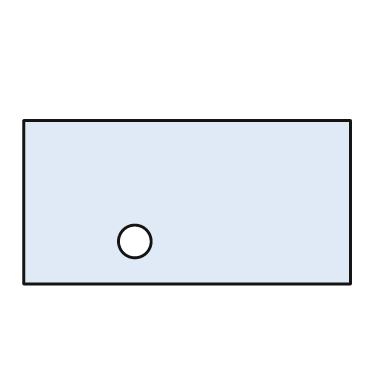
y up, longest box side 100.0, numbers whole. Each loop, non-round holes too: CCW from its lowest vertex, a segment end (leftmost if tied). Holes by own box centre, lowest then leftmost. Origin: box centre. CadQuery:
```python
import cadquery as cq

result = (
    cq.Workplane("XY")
    .moveTo(-50.0, -25.0)
    .lineTo(50.0, -25.0)
    .lineTo(50.0, 25.0)
    .lineTo(-50.0, 25.0)
    .close()
    .moveTo(-16.0, -12.0)
    .circle(5.0)
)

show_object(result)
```